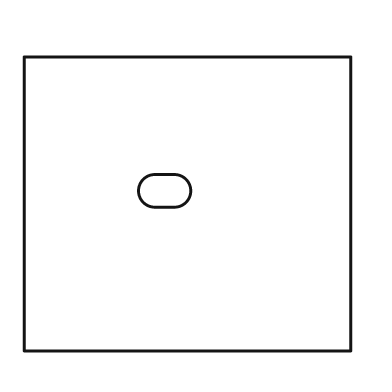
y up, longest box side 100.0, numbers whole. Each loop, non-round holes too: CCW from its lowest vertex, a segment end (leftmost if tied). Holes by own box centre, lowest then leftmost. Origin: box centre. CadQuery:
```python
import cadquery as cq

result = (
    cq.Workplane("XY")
    .moveTo(-50.0, -45.0)
    .lineTo(50.0, -45.0)
    .lineTo(50.0, 45.0)
    .lineTo(-50.0, 45.0)
    .close()
    .moveTo(-10.0, -1.0)
    .lineTo(-4.0, -1.0)
    .threePointArc((1.0, 4.0), (-4.0, 9.0))
    .lineTo(-10.0, 9.0)
    .threePointArc((-15.0, 4.0), (-10.0, -1.0))
    .close()
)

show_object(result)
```